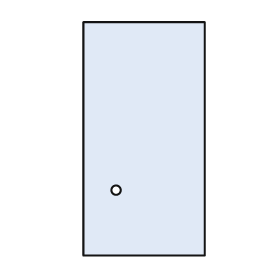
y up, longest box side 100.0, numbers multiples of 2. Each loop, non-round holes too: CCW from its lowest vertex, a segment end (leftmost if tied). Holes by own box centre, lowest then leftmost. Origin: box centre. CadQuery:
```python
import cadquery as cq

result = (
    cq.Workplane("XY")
    .moveTo(-26.0, -50.0)
    .lineTo(26.0, -50.0)
    .lineTo(26.0, 50.0)
    .lineTo(-26.0, 50.0)
    .close()
    .moveTo(-12.0, -22.0)
    .circle(2.0)
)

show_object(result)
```